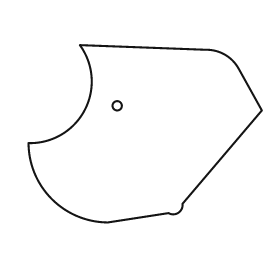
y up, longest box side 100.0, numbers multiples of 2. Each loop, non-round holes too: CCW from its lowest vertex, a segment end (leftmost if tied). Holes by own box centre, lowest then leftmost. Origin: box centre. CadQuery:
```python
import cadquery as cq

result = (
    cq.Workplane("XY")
    .moveTo(-16.0, -38.0)
    .lineTo(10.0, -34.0)
    .threePointArc((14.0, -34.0), (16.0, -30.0))
    .lineTo(50.0, 10.0)
    .lineTo(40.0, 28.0)
    .threePointArc((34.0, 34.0), (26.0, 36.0))
    .lineTo(-28.0, 38.0)
    .threePointArc((-26.0, 10.0), (-50.0, -4.0))
    .threePointArc((-40.0, -28.0), (-16.0, -38.0))
    .close()
    .moveTo(-12.0, 12.0)
    .circle(2.0)
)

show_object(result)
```